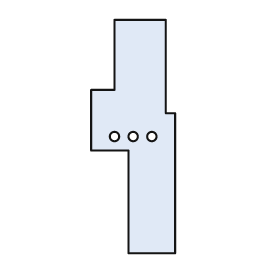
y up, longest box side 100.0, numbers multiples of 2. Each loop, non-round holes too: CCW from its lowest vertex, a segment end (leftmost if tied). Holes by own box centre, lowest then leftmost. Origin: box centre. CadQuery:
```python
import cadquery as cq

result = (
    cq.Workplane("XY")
    .moveTo(-2.0, -50.0)
    .lineTo(18.0, -50.0)
    .lineTo(18.0, 10.0)
    .lineTo(14.0, 10.0)
    .lineTo(14.0, 50.0)
    .lineTo(-8.0, 50.0)
    .lineTo(-8.0, 20.0)
    .lineTo(-18.0, 20.0)
    .lineTo(-18.0, -6.0)
    .lineTo(-2.0, -6.0)
    .close()
    .moveTo(-8.0, 0.0)
    .circle(2.0)
    .moveTo(0.0, 0.0)
    .circle(2.0)
    .moveTo(8.0, 0.0)
    .circle(2.0)
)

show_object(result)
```